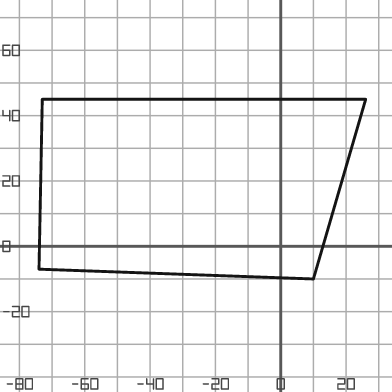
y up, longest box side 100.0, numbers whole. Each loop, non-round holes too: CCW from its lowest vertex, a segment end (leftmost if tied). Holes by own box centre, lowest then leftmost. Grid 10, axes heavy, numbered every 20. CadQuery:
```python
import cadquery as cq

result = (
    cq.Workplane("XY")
    .moveTo(10.0, -10.0)
    .lineTo(26.0, 45.0)
    .lineTo(-73.0, 45.0)
    .lineTo(-74.0, -7.0)
    .close()
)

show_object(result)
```